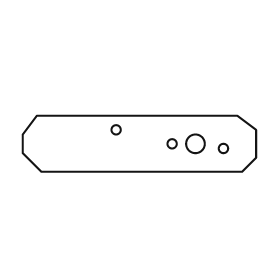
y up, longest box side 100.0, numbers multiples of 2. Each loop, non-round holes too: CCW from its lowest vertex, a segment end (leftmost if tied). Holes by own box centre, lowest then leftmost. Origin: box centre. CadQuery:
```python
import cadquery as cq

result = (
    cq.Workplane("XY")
    .moveTo(-42.0, -12.0)
    .lineTo(44.0, -12.0)
    .lineTo(50.0, -6.0)
    .lineTo(50.0, 6.0)
    .lineTo(42.0, 12.0)
    .lineTo(-44.0, 12.0)
    .lineTo(-50.0, 4.0)
    .lineTo(-50.0, -4.0)
    .close()
    .moveTo(36.0, -2.0)
    .circle(2.0)
    .moveTo(14.0, 0.0)
    .circle(2.0)
    .moveTo(24.0, 0.0)
    .circle(4.0)
    .moveTo(-10.0, 6.0)
    .circle(2.0)
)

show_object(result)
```